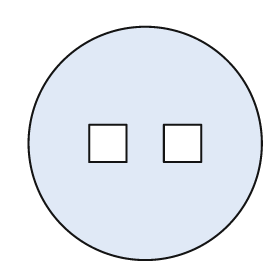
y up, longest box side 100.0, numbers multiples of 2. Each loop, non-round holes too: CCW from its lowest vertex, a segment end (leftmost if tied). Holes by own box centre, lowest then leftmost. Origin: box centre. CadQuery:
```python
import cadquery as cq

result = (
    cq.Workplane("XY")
    .moveTo(0.0, 0.0)
    .circle(50.0)
    .moveTo(-24.0, -8.0)
    .lineTo(-8.0, -8.0)
    .lineTo(-8.0, 8.0)
    .lineTo(-24.0, 8.0)
    .close()
    .moveTo(8.0, -8.0)
    .lineTo(24.0, -8.0)
    .lineTo(24.0, 8.0)
    .lineTo(8.0, 8.0)
    .close()
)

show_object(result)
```